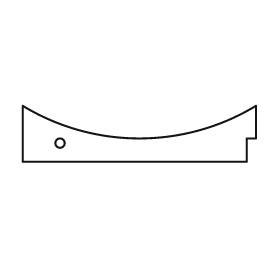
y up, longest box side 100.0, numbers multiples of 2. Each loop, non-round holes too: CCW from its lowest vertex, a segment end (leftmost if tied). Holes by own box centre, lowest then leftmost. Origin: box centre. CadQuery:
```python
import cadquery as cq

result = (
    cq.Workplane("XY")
    .moveTo(-50.0, -12.0)
    .lineTo(46.0, -12.0)
    .lineTo(46.0, -2.0)
    .lineTo(50.0, -2.0)
    .lineTo(50.0, 12.0)
    .threePointArc((0.0, -2.0), (-50.0, 12.0))
    .close()
    .moveTo(-34.0, -4.0)
    .circle(2.0)
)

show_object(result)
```